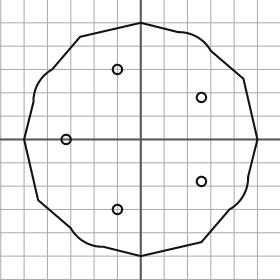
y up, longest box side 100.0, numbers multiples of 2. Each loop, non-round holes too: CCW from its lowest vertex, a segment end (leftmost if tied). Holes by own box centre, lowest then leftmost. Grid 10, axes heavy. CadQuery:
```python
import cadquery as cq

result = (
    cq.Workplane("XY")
    .moveTo(0.0, -50.0)
    .lineTo(26.0, -44.0)
    .lineTo(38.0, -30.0)
    .threePointArc((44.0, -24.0), (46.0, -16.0))
    .lineTo(50.0, 0.0)
    .lineTo(44.0, 26.0)
    .lineTo(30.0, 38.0)
    .threePointArc((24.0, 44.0), (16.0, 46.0))
    .lineTo(0.0, 50.0)
    .lineTo(-26.0, 44.0)
    .lineTo(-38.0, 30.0)
    .threePointArc((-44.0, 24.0), (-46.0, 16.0))
    .lineTo(-50.0, 0.0)
    .lineTo(-44.0, -26.0)
    .lineTo(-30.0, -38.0)
    .threePointArc((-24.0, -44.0), (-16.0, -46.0))
    .close()
    .moveTo(-10.0, -30.0)
    .circle(2.0)
    .moveTo(26.0, -18.0)
    .circle(2.0)
    .moveTo(-32.0, 0.0)
    .circle(2.0)
    .moveTo(26.0, 18.0)
    .circle(2.0)
    .moveTo(-10.0, 30.0)
    .circle(2.0)
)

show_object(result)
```